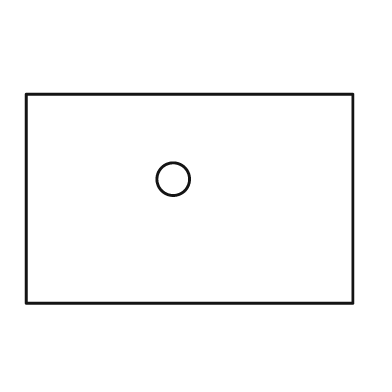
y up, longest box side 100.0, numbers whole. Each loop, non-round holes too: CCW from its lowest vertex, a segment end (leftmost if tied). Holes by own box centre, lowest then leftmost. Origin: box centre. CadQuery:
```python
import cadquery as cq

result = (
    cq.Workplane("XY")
    .moveTo(-50.0, -32.0)
    .lineTo(50.0, -32.0)
    .lineTo(50.0, 32.0)
    .lineTo(-50.0, 32.0)
    .close()
    .moveTo(-5.0, 6.0)
    .circle(5.0)
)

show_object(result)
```